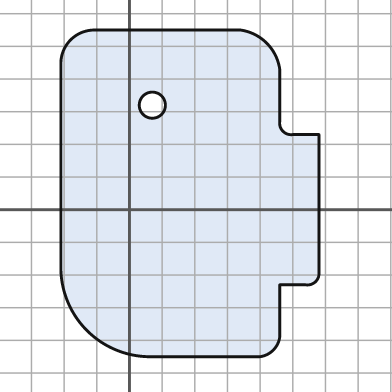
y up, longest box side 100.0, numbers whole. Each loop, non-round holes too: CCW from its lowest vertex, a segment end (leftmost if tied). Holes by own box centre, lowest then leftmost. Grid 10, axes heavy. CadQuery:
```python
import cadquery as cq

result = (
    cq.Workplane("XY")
    .moveTo(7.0, -45.0)
    .lineTo(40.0, -45.0)
    .threePointArc((44.0, -43.0), (46.0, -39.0))
    .lineTo(46.0, -23.0)
    .lineTo(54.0, -23.0)
    .threePointArc((57.0, -22.0), (58.0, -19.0))
    .lineTo(58.0, 23.0)
    .lineTo(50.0, 23.0)
    .threePointArc((47.0, 24.0), (46.0, 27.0))
    .lineTo(46.0, 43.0)
    .threePointArc((42.0, 51.0), (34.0, 55.0))
    .lineTo(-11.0, 55.0)
    .threePointArc((-18.0, 52.0), (-21.0, 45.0))
    .lineTo(-21.0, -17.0)
    .threePointArc((-13.0, -37.0), (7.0, -45.0))
    .close()
    .moveTo(7.0, 32.0)
    .circle(4.0)
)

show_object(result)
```